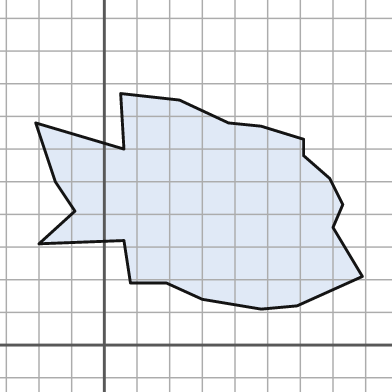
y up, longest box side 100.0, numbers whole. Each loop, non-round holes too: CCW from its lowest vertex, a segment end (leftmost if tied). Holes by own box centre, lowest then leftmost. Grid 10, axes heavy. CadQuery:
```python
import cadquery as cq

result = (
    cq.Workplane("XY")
    .moveTo(48.0, 11.0)
    .lineTo(59.0, 12.0)
    .lineTo(79.0, 21.0)
    .lineTo(70.0, 36.0)
    .lineTo(73.0, 43.0)
    .lineTo(69.0, 51.0)
    .lineTo(61.0, 58.0)
    .lineTo(61.0, 63.0)
    .lineTo(48.0, 67.0)
    .lineTo(38.0, 68.0)
    .lineTo(23.0, 75.0)
    .lineTo(5.0, 77.0)
    .lineTo(6.0, 60.0)
    .lineTo(-21.0, 68.0)
    .lineTo(-15.0, 50.0)
    .lineTo(-9.0, 41.0)
    .lineTo(-20.0, 31.0)
    .lineTo(6.0, 32.0)
    .lineTo(8.0, 19.0)
    .lineTo(19.0, 19.0)
    .lineTo(30.0, 14.0)
    .close()
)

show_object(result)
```